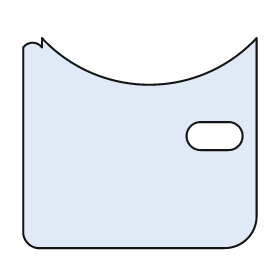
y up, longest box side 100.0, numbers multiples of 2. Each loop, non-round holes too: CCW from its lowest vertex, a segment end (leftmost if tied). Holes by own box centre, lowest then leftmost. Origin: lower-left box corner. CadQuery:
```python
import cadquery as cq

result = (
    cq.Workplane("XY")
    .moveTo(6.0, 0.0)
    .lineTo(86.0, 0.0)
    .threePointArc((96.0, 4.0), (100.0, 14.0))
    .lineTo(100.0, 90.0)
    .threePointArc((54.0, 70.0), (8.0, 90.0))
    .lineTo(8.0, 86.0)
    .threePointArc((4.0, 88.0), (0.0, 86.0))
    .lineTo(0.0, 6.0)
    .threePointArc((2.0, 2.0), (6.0, 0.0))
    .close()
    .moveTo(76.0, 42.0)
    .lineTo(88.0, 42.0)
    .threePointArc((94.0, 48.0), (88.0, 54.0))
    .lineTo(76.0, 54.0)
    .threePointArc((70.0, 48.0), (76.0, 42.0))
    .close()
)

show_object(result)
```